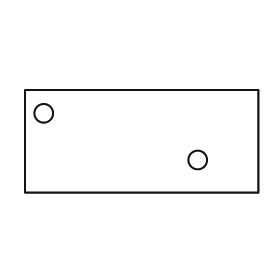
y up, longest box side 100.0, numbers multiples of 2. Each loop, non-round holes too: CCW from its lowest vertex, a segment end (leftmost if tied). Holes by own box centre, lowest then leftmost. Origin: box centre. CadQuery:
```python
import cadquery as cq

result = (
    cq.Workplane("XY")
    .moveTo(-50.0, -22.0)
    .lineTo(50.0, -22.0)
    .lineTo(50.0, 22.0)
    .lineTo(-50.0, 22.0)
    .close()
    .moveTo(24.0, -8.0)
    .circle(4.0)
    .moveTo(-42.0, 12.0)
    .circle(4.0)
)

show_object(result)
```